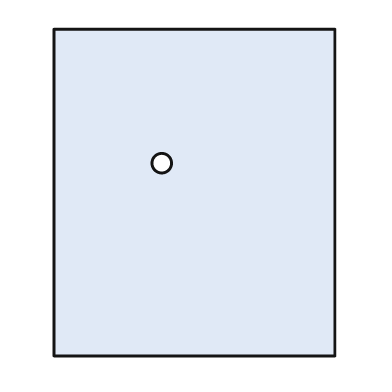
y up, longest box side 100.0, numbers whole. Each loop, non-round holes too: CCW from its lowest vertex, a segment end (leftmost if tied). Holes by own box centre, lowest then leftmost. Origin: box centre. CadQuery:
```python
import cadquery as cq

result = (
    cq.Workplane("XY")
    .moveTo(-43.0, -50.0)
    .lineTo(43.0, -50.0)
    .lineTo(43.0, 50.0)
    .lineTo(-43.0, 50.0)
    .close()
    .moveTo(-10.0, 9.0)
    .circle(3.0)
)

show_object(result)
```